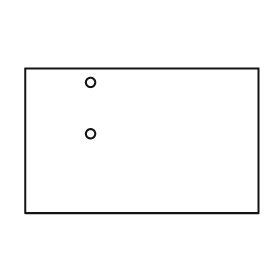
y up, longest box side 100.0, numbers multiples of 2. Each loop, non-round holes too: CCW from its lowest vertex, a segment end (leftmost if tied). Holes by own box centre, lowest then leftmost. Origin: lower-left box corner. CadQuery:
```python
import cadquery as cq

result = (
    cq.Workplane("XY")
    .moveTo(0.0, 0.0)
    .lineTo(100.0, 0.0)
    .lineTo(100.0, 62.0)
    .lineTo(0.0, 62.0)
    .close()
    .moveTo(28.0, 34.0)
    .circle(2.0)
    .moveTo(28.0, 56.0)
    .circle(2.0)
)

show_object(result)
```